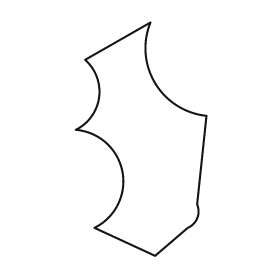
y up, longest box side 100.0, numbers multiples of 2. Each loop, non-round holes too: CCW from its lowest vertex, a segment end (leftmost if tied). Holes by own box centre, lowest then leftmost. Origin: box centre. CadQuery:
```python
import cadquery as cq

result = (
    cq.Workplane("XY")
    .moveTo(6.0, -50.0)
    .lineTo(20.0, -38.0)
    .threePointArc((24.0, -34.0), (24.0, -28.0))
    .lineTo(28.0, 10.0)
    .threePointArc((6.0, 24.0), (4.0, 50.0))
    .lineTo(-24.0, 34.0)
    .threePointArc((-18.0, 18.0), (-28.0, 4.0))
    .threePointArc((-8.0, -14.0), (-20.0, -38.0))
    .close()
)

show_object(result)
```